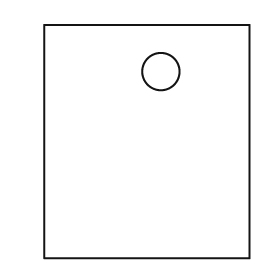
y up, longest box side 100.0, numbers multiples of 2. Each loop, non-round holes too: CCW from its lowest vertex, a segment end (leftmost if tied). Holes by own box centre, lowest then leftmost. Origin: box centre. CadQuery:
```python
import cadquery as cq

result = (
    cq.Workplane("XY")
    .moveTo(-44.0, -50.0)
    .lineTo(44.0, -50.0)
    .lineTo(44.0, 50.0)
    .lineTo(-44.0, 50.0)
    .close()
    .moveTo(6.0, 30.0)
    .circle(8.0)
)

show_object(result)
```